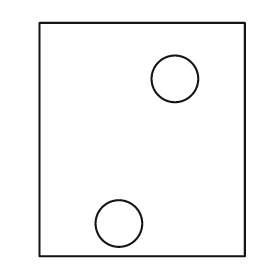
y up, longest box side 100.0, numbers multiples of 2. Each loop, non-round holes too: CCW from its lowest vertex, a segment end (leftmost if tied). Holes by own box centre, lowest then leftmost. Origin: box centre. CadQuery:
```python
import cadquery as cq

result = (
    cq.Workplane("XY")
    .moveTo(-44.0, -50.0)
    .lineTo(44.0, -50.0)
    .lineTo(44.0, 50.0)
    .lineTo(-44.0, 50.0)
    .close()
    .moveTo(-10.0, -36.0)
    .circle(10.0)
    .moveTo(14.0, 26.0)
    .circle(10.0)
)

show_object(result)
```